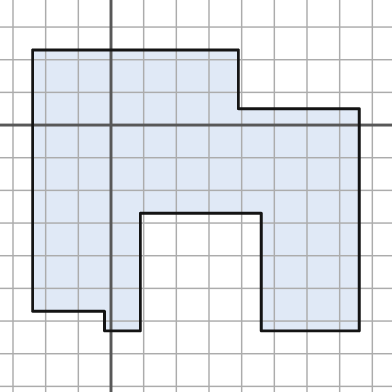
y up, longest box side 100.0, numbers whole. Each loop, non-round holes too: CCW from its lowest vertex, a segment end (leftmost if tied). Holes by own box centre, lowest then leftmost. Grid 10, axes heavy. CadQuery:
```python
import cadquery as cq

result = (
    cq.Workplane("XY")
    .moveTo(-2.0, -63.0)
    .lineTo(9.0, -63.0)
    .lineTo(9.0, -27.0)
    .lineTo(46.0, -27.0)
    .lineTo(46.0, -63.0)
    .lineTo(76.0, -63.0)
    .lineTo(76.0, 5.0)
    .lineTo(39.0, 5.0)
    .lineTo(39.0, 23.0)
    .lineTo(-24.0, 23.0)
    .lineTo(-24.0, -57.0)
    .lineTo(-2.0, -57.0)
    .close()
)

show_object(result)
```